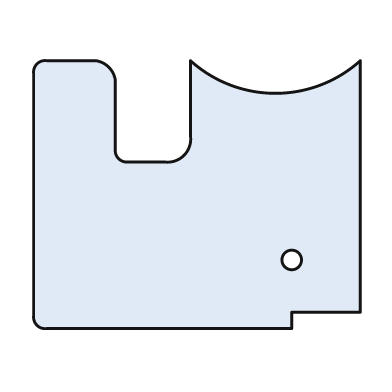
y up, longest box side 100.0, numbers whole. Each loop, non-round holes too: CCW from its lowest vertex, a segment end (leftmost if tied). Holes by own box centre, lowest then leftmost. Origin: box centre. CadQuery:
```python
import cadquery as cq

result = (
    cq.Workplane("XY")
    .moveTo(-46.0, -41.0)
    .lineTo(29.0, -41.0)
    .lineTo(29.0, -36.0)
    .lineTo(50.0, -36.0)
    .lineTo(50.0, 41.0)
    .threePointArc((24.0, 31.0), (-2.0, 41.0))
    .lineTo(-2.0, 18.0)
    .threePointArc((-4.0, 12.0), (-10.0, 10.0))
    .lineTo(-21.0, 10.0)
    .threePointArc((-24.0, 11.0), (-25.0, 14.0))
    .lineTo(-25.0, 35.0)
    .threePointArc((-27.0, 39.0), (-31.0, 41.0))
    .lineTo(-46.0, 41.0)
    .threePointArc((-49.0, 40.0), (-50.0, 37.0))
    .lineTo(-50.0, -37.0)
    .threePointArc((-49.0, -40.0), (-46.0, -41.0))
    .close()
    .moveTo(29.0, -20.0)
    .circle(3.0)
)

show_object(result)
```